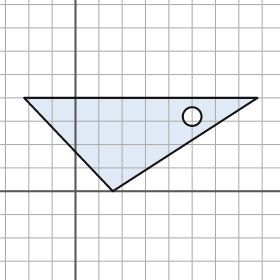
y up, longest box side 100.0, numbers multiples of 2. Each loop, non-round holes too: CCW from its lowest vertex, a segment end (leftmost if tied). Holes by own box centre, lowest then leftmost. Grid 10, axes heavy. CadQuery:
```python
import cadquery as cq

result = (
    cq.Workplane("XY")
    .moveTo(16.0, 0.0)
    .lineTo(78.0, 40.0)
    .lineTo(-22.0, 40.0)
    .close()
    .moveTo(50.0, 32.0)
    .circle(4.0)
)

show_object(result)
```